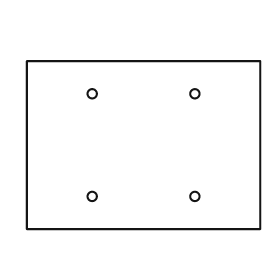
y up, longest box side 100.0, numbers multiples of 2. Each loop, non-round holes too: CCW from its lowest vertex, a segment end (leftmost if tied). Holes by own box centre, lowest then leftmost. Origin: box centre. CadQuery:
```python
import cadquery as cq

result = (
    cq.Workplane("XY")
    .moveTo(-50.0, -36.0)
    .lineTo(50.0, -36.0)
    .lineTo(50.0, 36.0)
    .lineTo(-50.0, 36.0)
    .close()
    .moveTo(-22.0, -22.0)
    .circle(2.0)
    .moveTo(22.0, -22.0)
    .circle(2.0)
    .moveTo(-22.0, 22.0)
    .circle(2.0)
    .moveTo(22.0, 22.0)
    .circle(2.0)
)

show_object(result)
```